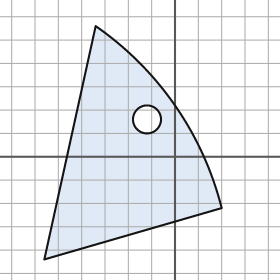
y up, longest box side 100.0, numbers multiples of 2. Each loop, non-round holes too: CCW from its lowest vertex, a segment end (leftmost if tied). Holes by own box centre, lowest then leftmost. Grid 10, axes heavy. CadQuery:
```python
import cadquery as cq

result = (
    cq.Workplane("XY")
    .moveTo(-56.0, -44.0)
    .lineTo(20.0, -22.0)
    .threePointArc((0.0, 22.0), (-34.0, 56.0))
    .close()
    .moveTo(-12.0, 16.0)
    .circle(6.0)
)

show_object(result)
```